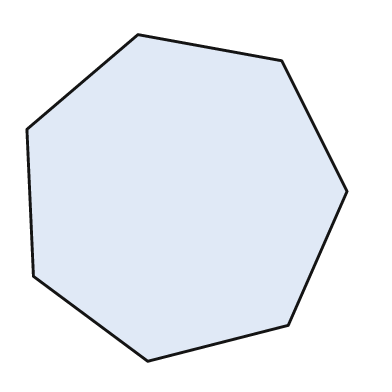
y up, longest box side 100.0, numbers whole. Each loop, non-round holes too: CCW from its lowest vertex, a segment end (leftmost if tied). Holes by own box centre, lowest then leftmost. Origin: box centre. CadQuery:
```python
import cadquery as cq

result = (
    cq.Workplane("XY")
    .moveTo(-12.0, -50.0)
    .lineTo(31.0, -39.0)
    .lineTo(49.0, 2.0)
    .lineTo(29.0, 42.0)
    .lineTo(-15.0, 50.0)
    .lineTo(-49.0, 21.0)
    .lineTo(-47.0, -24.0)
    .close()
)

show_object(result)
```